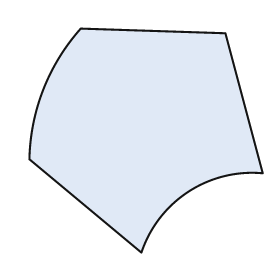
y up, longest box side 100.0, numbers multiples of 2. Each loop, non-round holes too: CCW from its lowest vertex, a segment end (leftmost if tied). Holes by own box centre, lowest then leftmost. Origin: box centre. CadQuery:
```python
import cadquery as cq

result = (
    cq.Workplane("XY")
    .moveTo(-2.0, -48.0)
    .threePointArc((18.0, -22.0), (50.0, -14.0))
    .lineTo(34.0, 46.0)
    .lineTo(-28.0, 48.0)
    .threePointArc((-44.0, 22.0), (-50.0, -8.0))
    .close()
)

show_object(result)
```